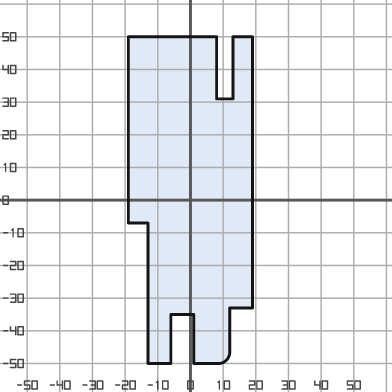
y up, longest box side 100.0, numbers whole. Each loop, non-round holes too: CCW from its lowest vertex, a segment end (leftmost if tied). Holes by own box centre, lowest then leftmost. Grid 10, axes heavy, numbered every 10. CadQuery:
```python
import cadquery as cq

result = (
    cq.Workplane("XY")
    .moveTo(-13.0, -50.0)
    .lineTo(-6.0, -50.0)
    .lineTo(-6.0, -35.0)
    .lineTo(1.0, -35.0)
    .lineTo(1.0, -50.0)
    .lineTo(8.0, -50.0)
    .threePointArc((11.0, -49.0), (12.0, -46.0))
    .lineTo(12.0, -33.0)
    .lineTo(19.0, -33.0)
    .lineTo(19.0, 50.0)
    .lineTo(13.0, 50.0)
    .lineTo(13.0, 31.0)
    .lineTo(8.0, 31.0)
    .lineTo(8.0, 50.0)
    .lineTo(-19.0, 50.0)
    .lineTo(-19.0, -7.0)
    .lineTo(-13.0, -7.0)
    .close()
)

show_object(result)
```